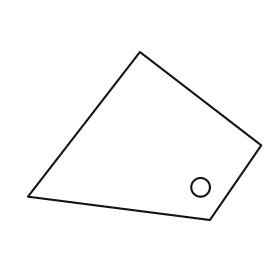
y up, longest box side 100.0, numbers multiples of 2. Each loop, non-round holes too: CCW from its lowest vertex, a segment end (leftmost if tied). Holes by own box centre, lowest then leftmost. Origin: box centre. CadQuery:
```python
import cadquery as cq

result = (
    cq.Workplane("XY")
    .moveTo(28.0, -36.0)
    .lineTo(50.0, -4.0)
    .lineTo(-2.0, 36.0)
    .lineTo(-50.0, -26.0)
    .close()
    .moveTo(24.0, -22.0)
    .circle(4.0)
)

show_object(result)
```